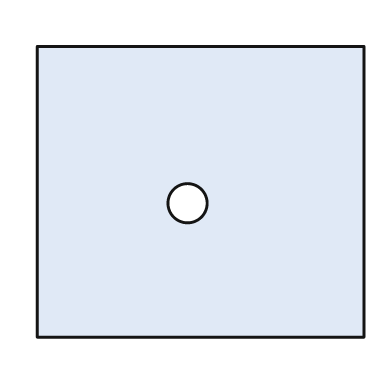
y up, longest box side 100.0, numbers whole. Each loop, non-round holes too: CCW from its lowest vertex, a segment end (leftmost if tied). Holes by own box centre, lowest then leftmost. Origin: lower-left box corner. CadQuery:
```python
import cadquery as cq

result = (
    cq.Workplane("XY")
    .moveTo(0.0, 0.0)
    .lineTo(100.0, 0.0)
    .lineTo(100.0, 89.0)
    .lineTo(0.0, 89.0)
    .close()
    .moveTo(46.0, 41.0)
    .circle(6.0)
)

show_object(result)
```